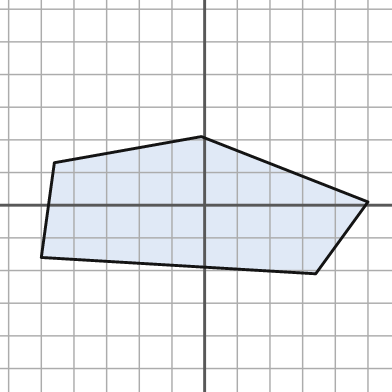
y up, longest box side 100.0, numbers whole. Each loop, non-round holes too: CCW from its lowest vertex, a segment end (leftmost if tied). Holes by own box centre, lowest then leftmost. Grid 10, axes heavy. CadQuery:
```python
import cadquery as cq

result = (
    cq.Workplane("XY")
    .moveTo(34.0, -21.0)
    .lineTo(50.0, 1.0)
    .lineTo(-1.0, 21.0)
    .lineTo(-46.0, 13.0)
    .lineTo(-50.0, -16.0)
    .close()
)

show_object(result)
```